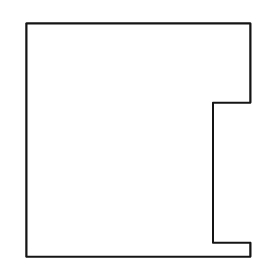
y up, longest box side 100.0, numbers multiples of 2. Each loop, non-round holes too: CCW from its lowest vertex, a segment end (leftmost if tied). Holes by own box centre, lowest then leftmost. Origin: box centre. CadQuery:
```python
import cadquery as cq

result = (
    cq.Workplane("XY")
    .moveTo(-48.0, -50.0)
    .lineTo(48.0, -50.0)
    .lineTo(48.0, -44.0)
    .lineTo(32.0, -44.0)
    .lineTo(32.0, 16.0)
    .lineTo(48.0, 16.0)
    .lineTo(48.0, 50.0)
    .lineTo(-48.0, 50.0)
    .close()
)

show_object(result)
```